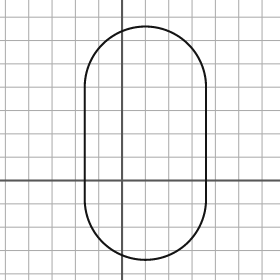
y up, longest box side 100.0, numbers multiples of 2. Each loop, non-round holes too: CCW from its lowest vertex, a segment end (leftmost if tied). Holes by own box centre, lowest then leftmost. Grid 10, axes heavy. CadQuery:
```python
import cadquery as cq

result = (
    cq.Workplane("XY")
    .moveTo(-16.0, -8.0)
    .threePointArc((10.0, -34.0), (36.0, -8.0))
    .lineTo(36.0, 40.0)
    .threePointArc((10.0, 66.0), (-16.0, 40.0))
    .close()
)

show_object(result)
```